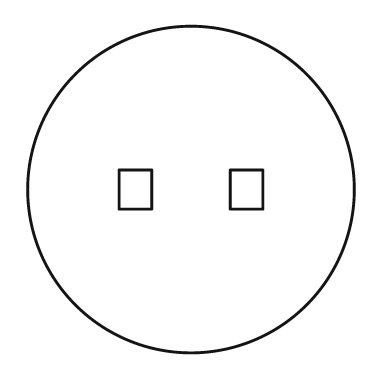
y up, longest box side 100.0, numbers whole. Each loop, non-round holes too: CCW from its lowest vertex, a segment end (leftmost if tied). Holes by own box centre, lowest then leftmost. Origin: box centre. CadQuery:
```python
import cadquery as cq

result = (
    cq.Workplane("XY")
    .moveTo(0.0, 0.0)
    .circle(50.0)
    .moveTo(-22.0, -6.0)
    .lineTo(-12.0, -6.0)
    .lineTo(-12.0, 6.0)
    .lineTo(-22.0, 6.0)
    .close()
    .moveTo(12.0, -6.0)
    .lineTo(22.0, -6.0)
    .lineTo(22.0, 6.0)
    .lineTo(12.0, 6.0)
    .close()
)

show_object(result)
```